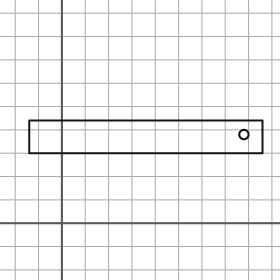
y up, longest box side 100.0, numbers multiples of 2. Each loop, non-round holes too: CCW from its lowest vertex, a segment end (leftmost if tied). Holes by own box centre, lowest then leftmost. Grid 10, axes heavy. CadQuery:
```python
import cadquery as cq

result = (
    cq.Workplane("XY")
    .moveTo(-14.0, 30.0)
    .lineTo(86.0, 30.0)
    .lineTo(86.0, 44.0)
    .lineTo(-14.0, 44.0)
    .close()
    .moveTo(78.0, 38.0)
    .circle(2.0)
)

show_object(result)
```